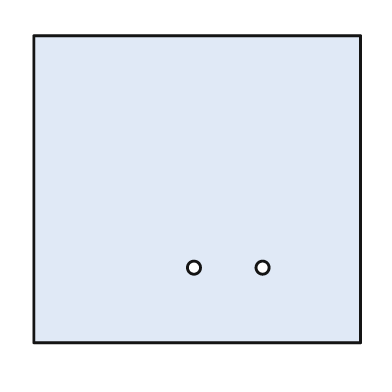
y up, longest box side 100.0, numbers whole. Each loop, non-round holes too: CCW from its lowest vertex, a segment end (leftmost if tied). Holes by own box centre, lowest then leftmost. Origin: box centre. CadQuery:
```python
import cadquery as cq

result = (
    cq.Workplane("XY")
    .moveTo(-50.0, -47.0)
    .lineTo(50.0, -47.0)
    .lineTo(50.0, 47.0)
    .lineTo(-50.0, 47.0)
    .close()
    .moveTo(-1.0, -24.0)
    .circle(2.0)
    .moveTo(20.0, -24.0)
    .circle(2.0)
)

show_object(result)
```